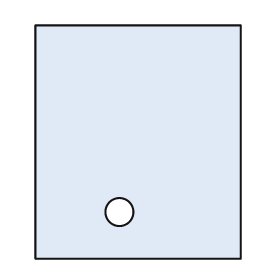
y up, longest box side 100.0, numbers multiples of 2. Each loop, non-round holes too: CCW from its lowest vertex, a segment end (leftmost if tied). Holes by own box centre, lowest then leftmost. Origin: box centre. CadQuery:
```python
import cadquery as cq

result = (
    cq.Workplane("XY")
    .moveTo(-44.0, -50.0)
    .lineTo(44.0, -50.0)
    .lineTo(44.0, 50.0)
    .lineTo(-44.0, 50.0)
    .close()
    .moveTo(-8.0, -30.0)
    .circle(6.0)
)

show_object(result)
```